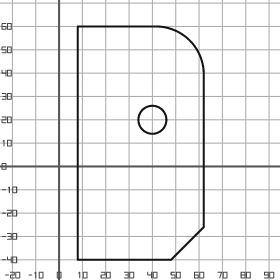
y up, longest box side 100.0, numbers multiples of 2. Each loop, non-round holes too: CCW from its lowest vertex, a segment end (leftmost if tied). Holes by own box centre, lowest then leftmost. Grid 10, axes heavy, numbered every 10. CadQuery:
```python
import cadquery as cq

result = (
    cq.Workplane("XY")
    .moveTo(8.0, -40.0)
    .lineTo(48.0, -40.0)
    .lineTo(62.0, -26.0)
    .lineTo(62.0, 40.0)
    .threePointArc((56.0, 54.0), (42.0, 60.0))
    .lineTo(8.0, 60.0)
    .close()
    .moveTo(40.0, 20.0)
    .circle(6.0)
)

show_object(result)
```